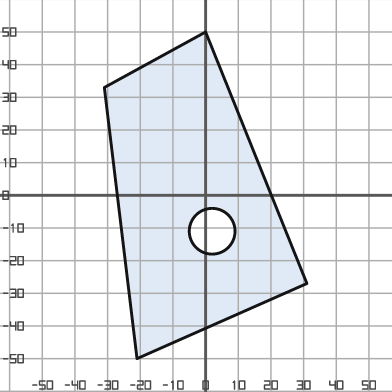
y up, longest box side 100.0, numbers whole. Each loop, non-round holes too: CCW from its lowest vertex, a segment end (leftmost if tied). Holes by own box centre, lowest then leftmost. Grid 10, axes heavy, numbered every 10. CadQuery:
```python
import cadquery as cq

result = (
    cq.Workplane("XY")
    .moveTo(-21.0, -50.0)
    .lineTo(31.0, -27.0)
    .lineTo(0.0, 50.0)
    .lineTo(-31.0, 33.0)
    .close()
    .moveTo(2.0, -11.0)
    .circle(7.0)
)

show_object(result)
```